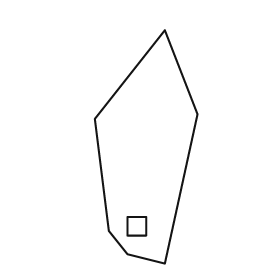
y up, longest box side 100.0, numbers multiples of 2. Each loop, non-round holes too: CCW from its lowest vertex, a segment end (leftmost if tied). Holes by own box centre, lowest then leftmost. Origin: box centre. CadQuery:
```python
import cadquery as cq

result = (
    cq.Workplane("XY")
    .moveTo(8.0, -50.0)
    .lineTo(22.0, 14.0)
    .lineTo(8.0, 50.0)
    .lineTo(-22.0, 12.0)
    .lineTo(-16.0, -36.0)
    .lineTo(-8.0, -46.0)
    .close()
    .moveTo(-8.0, -38.0)
    .lineTo(0.0, -38.0)
    .lineTo(0.0, -30.0)
    .lineTo(-8.0, -30.0)
    .close()
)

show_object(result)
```